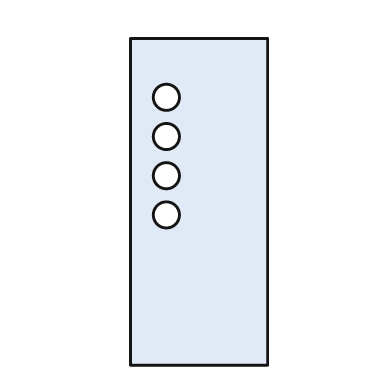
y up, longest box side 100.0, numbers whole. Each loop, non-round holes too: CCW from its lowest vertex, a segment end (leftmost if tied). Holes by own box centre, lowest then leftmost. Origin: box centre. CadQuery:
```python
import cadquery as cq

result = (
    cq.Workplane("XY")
    .moveTo(-21.0, -50.0)
    .lineTo(21.0, -50.0)
    .lineTo(21.0, 50.0)
    .lineTo(-21.0, 50.0)
    .close()
    .moveTo(-10.0, -4.0)
    .circle(4.0)
    .moveTo(-10.0, 8.0)
    .circle(4.0)
    .moveTo(-10.0, 20.0)
    .circle(4.0)
    .moveTo(-10.0, 32.0)
    .circle(4.0)
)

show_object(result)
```